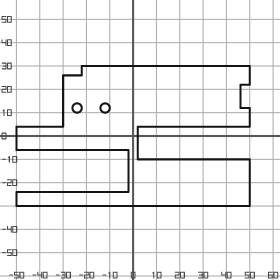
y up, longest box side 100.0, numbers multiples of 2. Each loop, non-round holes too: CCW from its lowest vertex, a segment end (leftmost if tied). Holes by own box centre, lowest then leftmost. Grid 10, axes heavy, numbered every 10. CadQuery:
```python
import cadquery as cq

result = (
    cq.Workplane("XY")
    .moveTo(-50.0, -30.0)
    .lineTo(50.0, -30.0)
    .lineTo(50.0, -10.0)
    .lineTo(2.0, -10.0)
    .lineTo(2.0, 4.0)
    .lineTo(50.0, 4.0)
    .lineTo(50.0, 12.0)
    .lineTo(46.0, 12.0)
    .lineTo(46.0, 22.0)
    .lineTo(50.0, 22.0)
    .lineTo(50.0, 30.0)
    .lineTo(-22.0, 30.0)
    .lineTo(-22.0, 26.0)
    .lineTo(-30.0, 26.0)
    .lineTo(-30.0, 4.0)
    .lineTo(-50.0, 4.0)
    .lineTo(-50.0, -6.0)
    .lineTo(-2.0, -6.0)
    .lineTo(-2.0, -24.0)
    .lineTo(-50.0, -24.0)
    .close()
    .moveTo(-24.0, 12.0)
    .circle(2.0)
    .moveTo(-12.0, 12.0)
    .circle(2.0)
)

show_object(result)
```